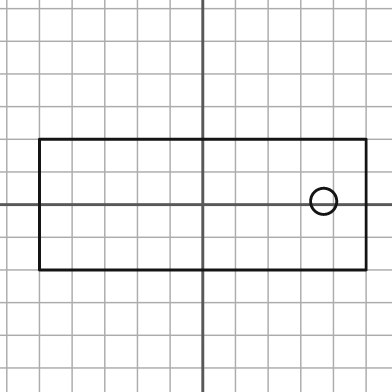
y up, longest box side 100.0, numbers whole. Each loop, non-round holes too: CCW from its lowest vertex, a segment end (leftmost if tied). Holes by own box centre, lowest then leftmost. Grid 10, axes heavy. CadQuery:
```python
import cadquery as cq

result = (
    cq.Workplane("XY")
    .moveTo(-50.0, -20.0)
    .lineTo(50.0, -20.0)
    .lineTo(50.0, 20.0)
    .lineTo(-50.0, 20.0)
    .close()
    .moveTo(37.0, 1.0)
    .circle(4.0)
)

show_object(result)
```